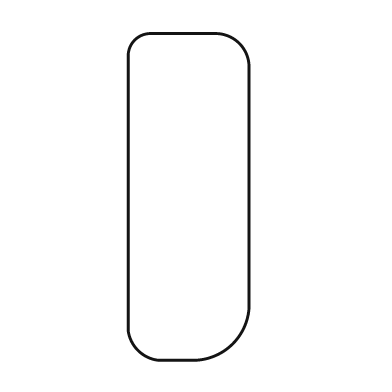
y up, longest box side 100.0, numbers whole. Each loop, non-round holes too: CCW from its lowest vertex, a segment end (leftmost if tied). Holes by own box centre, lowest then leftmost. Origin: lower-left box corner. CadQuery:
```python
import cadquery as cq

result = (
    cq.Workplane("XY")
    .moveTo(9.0, 0.0)
    .lineTo(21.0, 0.0)
    .threePointArc((32.0, 5.0), (37.0, 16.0))
    .lineTo(37.0, 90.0)
    .threePointArc((34.0, 97.0), (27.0, 100.0))
    .lineTo(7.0, 100.0)
    .threePointArc((2.0, 98.0), (0.0, 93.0))
    .lineTo(0.0, 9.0)
    .threePointArc((3.0, 3.0), (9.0, 0.0))
    .close()
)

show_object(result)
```